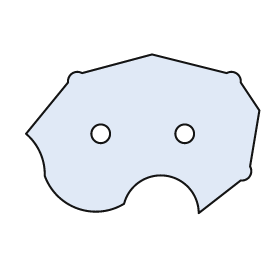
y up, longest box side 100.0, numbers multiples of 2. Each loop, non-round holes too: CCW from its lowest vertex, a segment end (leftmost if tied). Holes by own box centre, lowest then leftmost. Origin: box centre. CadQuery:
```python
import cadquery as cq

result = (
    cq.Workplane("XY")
    .moveTo(24.0, -34.0)
    .lineTo(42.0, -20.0)
    .threePointArc((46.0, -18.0), (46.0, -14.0))
    .lineTo(50.0, 10.0)
    .lineTo(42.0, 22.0)
    .threePointArc((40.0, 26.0), (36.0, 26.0))
    .lineTo(4.0, 34.0)
    .lineTo(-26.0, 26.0)
    .threePointArc((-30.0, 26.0), (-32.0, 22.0))
    .lineTo(-50.0, 0.0)
    .threePointArc((-44.0, -8.0), (-42.0, -18.0))
    .threePointArc((-28.0, -32.0), (-8.0, -30.0))
    .threePointArc((10.0, -18.0), (24.0, -34.0))
    .close()
    .moveTo(-18.0, 0.0)
    .circle(4.0)
    .moveTo(18.0, 0.0)
    .circle(4.0)
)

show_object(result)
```